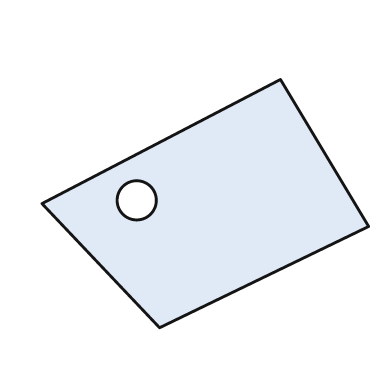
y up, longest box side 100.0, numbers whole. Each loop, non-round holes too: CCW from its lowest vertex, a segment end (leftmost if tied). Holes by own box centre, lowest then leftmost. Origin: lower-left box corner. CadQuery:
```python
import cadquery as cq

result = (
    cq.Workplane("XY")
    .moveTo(36.0, 0.0)
    .lineTo(100.0, 31.0)
    .lineTo(73.0, 76.0)
    .lineTo(0.0, 38.0)
    .close()
    .moveTo(29.0, 39.0)
    .circle(6.0)
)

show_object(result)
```